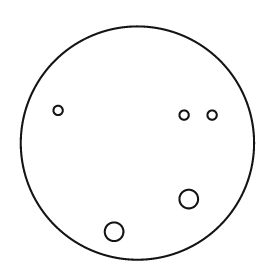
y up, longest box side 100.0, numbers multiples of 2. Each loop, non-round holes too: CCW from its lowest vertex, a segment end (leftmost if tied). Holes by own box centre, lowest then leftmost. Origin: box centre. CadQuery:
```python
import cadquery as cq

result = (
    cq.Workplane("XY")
    .moveTo(0.0, 0.0)
    .circle(50.0)
    .moveTo(-10.0, -38.0)
    .circle(4.0)
    .moveTo(22.0, -24.0)
    .circle(4.0)
    .moveTo(20.0, 12.0)
    .circle(2.0)
    .moveTo(32.0, 12.0)
    .circle(2.0)
    .moveTo(-34.0, 14.0)
    .circle(2.0)
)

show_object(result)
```